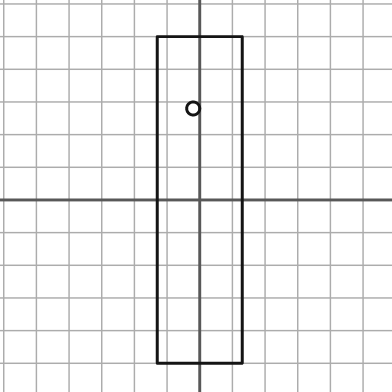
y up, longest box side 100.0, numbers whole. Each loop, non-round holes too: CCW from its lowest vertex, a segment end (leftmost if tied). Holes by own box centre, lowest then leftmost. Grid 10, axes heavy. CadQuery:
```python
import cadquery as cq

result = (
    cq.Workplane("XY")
    .moveTo(-13.0, -50.0)
    .lineTo(13.0, -50.0)
    .lineTo(13.0, 50.0)
    .lineTo(-13.0, 50.0)
    .close()
    .moveTo(-2.0, 28.0)
    .circle(2.0)
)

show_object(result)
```